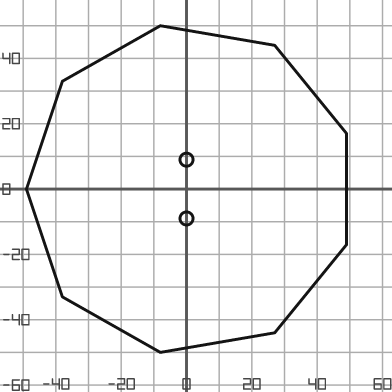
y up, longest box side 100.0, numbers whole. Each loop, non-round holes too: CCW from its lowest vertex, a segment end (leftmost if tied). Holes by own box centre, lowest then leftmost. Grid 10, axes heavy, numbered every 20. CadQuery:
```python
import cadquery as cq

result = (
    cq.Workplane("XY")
    .moveTo(-8.0, -50.0)
    .lineTo(27.0, -44.0)
    .lineTo(49.0, -17.0)
    .lineTo(49.0, 17.0)
    .lineTo(27.0, 44.0)
    .lineTo(-8.0, 50.0)
    .lineTo(-38.0, 33.0)
    .lineTo(-49.0, 0.0)
    .lineTo(-38.0, -33.0)
    .close()
    .moveTo(0.0, -9.0)
    .circle(2.0)
    .moveTo(0.0, 9.0)
    .circle(2.0)
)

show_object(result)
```